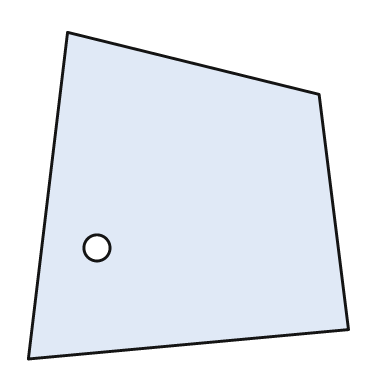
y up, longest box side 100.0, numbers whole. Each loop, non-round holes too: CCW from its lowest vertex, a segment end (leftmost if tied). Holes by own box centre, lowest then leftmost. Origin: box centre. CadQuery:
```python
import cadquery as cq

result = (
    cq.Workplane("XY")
    .moveTo(-49.0, -50.0)
    .lineTo(49.0, -41.0)
    .lineTo(40.0, 31.0)
    .lineTo(-37.0, 50.0)
    .close()
    .moveTo(-28.0, -16.0)
    .circle(4.0)
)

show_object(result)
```